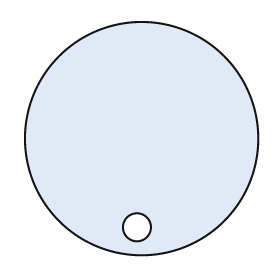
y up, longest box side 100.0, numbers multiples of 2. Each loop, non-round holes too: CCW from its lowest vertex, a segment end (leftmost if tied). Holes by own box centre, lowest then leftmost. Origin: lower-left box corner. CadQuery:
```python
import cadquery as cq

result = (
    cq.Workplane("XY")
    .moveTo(50.0, 50.0)
    .circle(50.0)
    .moveTo(48.0, 12.0)
    .circle(6.0)
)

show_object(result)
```